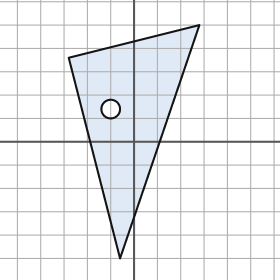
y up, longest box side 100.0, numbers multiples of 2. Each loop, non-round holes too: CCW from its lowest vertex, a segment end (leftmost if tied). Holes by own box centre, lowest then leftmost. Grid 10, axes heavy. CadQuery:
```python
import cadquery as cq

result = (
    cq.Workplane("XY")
    .moveTo(-6.0, -50.0)
    .lineTo(28.0, 50.0)
    .lineTo(-28.0, 36.0)
    .close()
    .moveTo(-10.0, 14.0)
    .circle(4.0)
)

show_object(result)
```